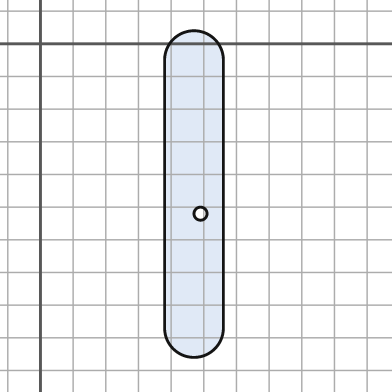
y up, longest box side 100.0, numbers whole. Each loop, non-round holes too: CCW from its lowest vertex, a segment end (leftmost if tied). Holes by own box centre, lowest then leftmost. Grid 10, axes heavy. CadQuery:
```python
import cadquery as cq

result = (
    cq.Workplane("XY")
    .moveTo(38.0, -87.0)
    .threePointArc((47.0, -96.0), (56.0, -87.0))
    .lineTo(56.0, -5.0)
    .threePointArc((47.0, 4.0), (38.0, -5.0))
    .close()
    .moveTo(49.0, -52.0)
    .circle(2.0)
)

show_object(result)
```